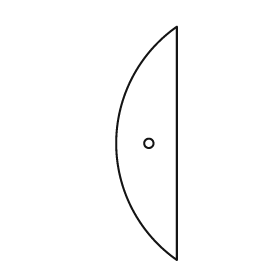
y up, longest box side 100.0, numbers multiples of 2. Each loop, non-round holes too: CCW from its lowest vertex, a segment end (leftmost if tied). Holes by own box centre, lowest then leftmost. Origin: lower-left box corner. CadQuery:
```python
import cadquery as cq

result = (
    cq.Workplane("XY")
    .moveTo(26.0, 0.0)
    .lineTo(26.0, 100.0)
    .threePointArc((0.0, 50.0), (26.0, 0.0))
    .close()
    .moveTo(14.0, 50.0)
    .circle(2.0)
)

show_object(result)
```